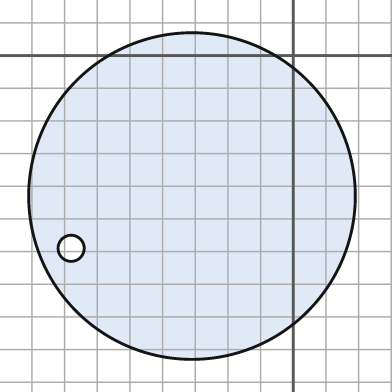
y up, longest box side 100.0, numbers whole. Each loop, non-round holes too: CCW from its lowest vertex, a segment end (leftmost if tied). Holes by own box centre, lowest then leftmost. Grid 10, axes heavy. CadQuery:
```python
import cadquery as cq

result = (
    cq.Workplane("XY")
    .moveTo(-31.0, -43.0)
    .circle(50.0)
    .moveTo(-68.0, -59.0)
    .circle(4.0)
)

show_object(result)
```